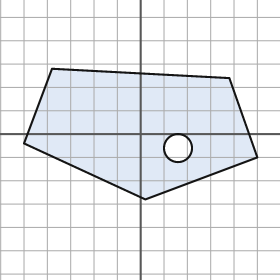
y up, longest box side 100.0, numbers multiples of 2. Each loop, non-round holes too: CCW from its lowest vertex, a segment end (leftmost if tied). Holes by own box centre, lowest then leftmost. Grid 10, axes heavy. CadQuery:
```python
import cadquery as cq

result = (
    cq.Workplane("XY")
    .moveTo(2.0, -28.0)
    .lineTo(50.0, -10.0)
    .lineTo(38.0, 24.0)
    .lineTo(-38.0, 28.0)
    .lineTo(-50.0, -4.0)
    .close()
    .moveTo(16.0, -6.0)
    .circle(6.0)
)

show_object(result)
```